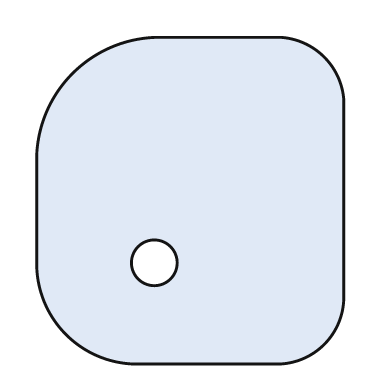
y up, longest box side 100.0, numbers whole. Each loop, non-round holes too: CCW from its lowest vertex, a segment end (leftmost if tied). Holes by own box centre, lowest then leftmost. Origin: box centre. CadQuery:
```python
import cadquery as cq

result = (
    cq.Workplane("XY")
    .moveTo(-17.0, -50.0)
    .lineTo(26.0, -50.0)
    .threePointArc((41.0, -44.0), (47.0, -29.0))
    .lineTo(47.0, 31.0)
    .threePointArc((41.0, 44.0), (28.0, 50.0))
    .lineTo(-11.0, 50.0)
    .threePointArc((-36.0, 39.0), (-47.0, 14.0))
    .lineTo(-47.0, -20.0)
    .threePointArc((-38.0, -41.0), (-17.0, -50.0))
    .close()
    .moveTo(-11.0, -19.0)
    .circle(7.0)
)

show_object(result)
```